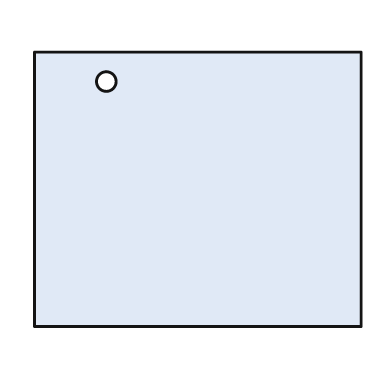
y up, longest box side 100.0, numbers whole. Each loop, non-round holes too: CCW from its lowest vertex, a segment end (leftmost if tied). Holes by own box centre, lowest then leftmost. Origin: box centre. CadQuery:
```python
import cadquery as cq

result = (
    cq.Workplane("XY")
    .moveTo(-50.0, -42.0)
    .lineTo(50.0, -42.0)
    .lineTo(50.0, 42.0)
    .lineTo(-50.0, 42.0)
    .close()
    .moveTo(-28.0, 33.0)
    .circle(3.0)
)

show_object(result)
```